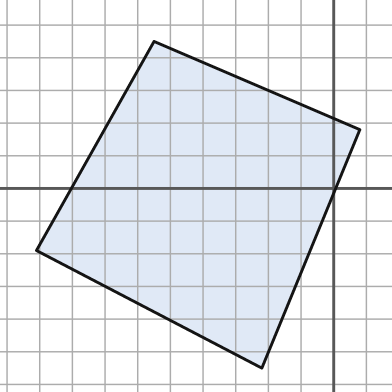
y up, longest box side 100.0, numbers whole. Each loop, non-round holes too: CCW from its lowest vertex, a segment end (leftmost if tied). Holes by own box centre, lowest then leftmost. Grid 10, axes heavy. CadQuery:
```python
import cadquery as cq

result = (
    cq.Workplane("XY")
    .moveTo(-22.0, -55.0)
    .lineTo(8.0, 18.0)
    .lineTo(-55.0, 45.0)
    .lineTo(-91.0, -19.0)
    .close()
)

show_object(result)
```